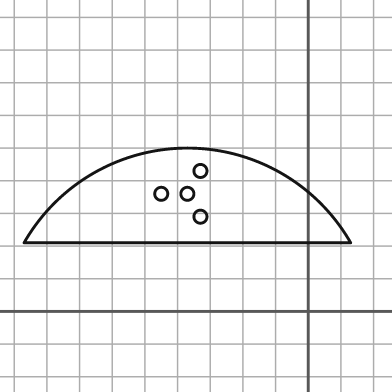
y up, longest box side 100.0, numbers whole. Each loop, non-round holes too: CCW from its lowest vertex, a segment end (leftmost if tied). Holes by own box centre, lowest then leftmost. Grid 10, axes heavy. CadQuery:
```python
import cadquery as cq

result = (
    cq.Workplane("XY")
    .moveTo(-87.0, 21.0)
    .lineTo(13.0, 21.0)
    .threePointArc((-37.0, 50.0), (-87.0, 21.0))
    .close()
    .moveTo(-33.0, 29.0)
    .circle(2.0)
    .moveTo(-45.0, 36.0)
    .circle(2.0)
    .moveTo(-37.0, 36.0)
    .circle(2.0)
    .moveTo(-33.0, 43.0)
    .circle(2.0)
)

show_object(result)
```